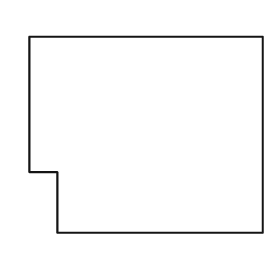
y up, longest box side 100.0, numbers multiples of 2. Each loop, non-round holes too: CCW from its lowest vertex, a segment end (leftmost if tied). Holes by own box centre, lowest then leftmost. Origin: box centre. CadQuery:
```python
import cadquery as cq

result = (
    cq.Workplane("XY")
    .moveTo(-38.0, -42.0)
    .lineTo(50.0, -42.0)
    .lineTo(50.0, 42.0)
    .lineTo(-50.0, 42.0)
    .lineTo(-50.0, -16.0)
    .lineTo(-38.0, -16.0)
    .close()
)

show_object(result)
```